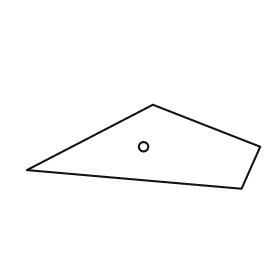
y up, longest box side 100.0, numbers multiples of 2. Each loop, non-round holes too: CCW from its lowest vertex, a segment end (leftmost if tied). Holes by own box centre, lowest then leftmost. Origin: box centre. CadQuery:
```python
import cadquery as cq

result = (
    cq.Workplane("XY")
    .moveTo(42.0, -18.0)
    .lineTo(50.0, 0.0)
    .lineTo(4.0, 18.0)
    .lineTo(-50.0, -10.0)
    .close()
    .moveTo(0.0, 0.0)
    .circle(2.0)
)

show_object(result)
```